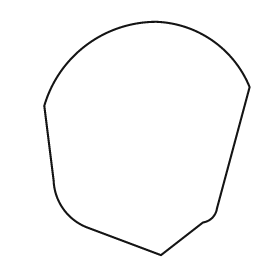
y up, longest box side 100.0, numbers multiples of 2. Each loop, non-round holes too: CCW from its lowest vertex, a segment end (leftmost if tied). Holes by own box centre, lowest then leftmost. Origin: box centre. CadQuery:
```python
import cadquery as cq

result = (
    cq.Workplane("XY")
    .moveTo(6.0, -50.0)
    .lineTo(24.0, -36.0)
    .threePointArc((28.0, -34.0), (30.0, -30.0))
    .lineTo(44.0, 22.0)
    .threePointArc((28.0, 42.0), (4.0, 50.0))
    .threePointArc((-26.0, 40.0), (-44.0, 14.0))
    .lineTo(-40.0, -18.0)
    .threePointArc((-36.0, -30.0), (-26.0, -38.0))
    .close()
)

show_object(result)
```